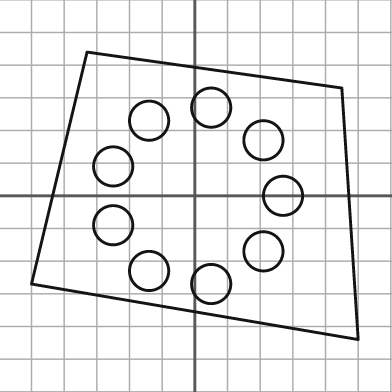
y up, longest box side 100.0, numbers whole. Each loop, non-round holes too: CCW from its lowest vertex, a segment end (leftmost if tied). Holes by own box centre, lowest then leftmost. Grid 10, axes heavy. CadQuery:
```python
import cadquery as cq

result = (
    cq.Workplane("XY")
    .moveTo(50.0, -44.0)
    .lineTo(45.0, 33.0)
    .lineTo(-33.0, 44.0)
    .lineTo(-50.0, -27.0)
    .close()
    .moveTo(5.0, -27.0)
    .circle(6.0)
    .moveTo(-14.0, -23.0)
    .circle(6.0)
    .moveTo(21.0, -17.0)
    .circle(6.0)
    .moveTo(-25.0, -9.0)
    .circle(6.0)
    .moveTo(27.0, 0.0)
    .circle(6.0)
    .moveTo(-25.0, 9.0)
    .circle(6.0)
    .moveTo(21.0, 17.0)
    .circle(6.0)
    .moveTo(-14.0, 23.0)
    .circle(6.0)
    .moveTo(5.0, 27.0)
    .circle(6.0)
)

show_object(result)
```